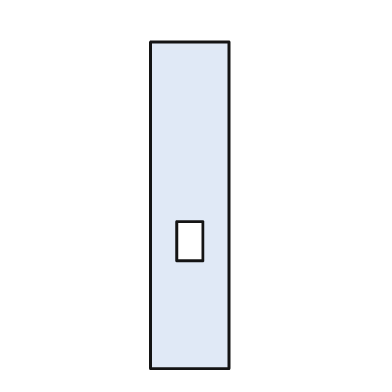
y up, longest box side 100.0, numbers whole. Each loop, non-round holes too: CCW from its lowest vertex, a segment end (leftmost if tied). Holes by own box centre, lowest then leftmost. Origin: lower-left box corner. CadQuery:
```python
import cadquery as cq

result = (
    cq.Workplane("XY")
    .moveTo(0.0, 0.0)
    .lineTo(24.0, 0.0)
    .lineTo(24.0, 100.0)
    .lineTo(0.0, 100.0)
    .close()
    .moveTo(8.0, 33.0)
    .lineTo(16.0, 33.0)
    .lineTo(16.0, 45.0)
    .lineTo(8.0, 45.0)
    .close()
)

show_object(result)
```